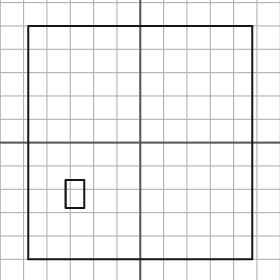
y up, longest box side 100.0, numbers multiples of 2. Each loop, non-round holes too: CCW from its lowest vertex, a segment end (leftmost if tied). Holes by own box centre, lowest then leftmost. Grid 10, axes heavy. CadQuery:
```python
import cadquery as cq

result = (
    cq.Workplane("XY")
    .moveTo(-48.0, -50.0)
    .lineTo(48.0, -50.0)
    .lineTo(48.0, 50.0)
    .lineTo(-48.0, 50.0)
    .close()
    .moveTo(-32.0, -28.0)
    .lineTo(-24.0, -28.0)
    .lineTo(-24.0, -16.0)
    .lineTo(-32.0, -16.0)
    .close()
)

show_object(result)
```